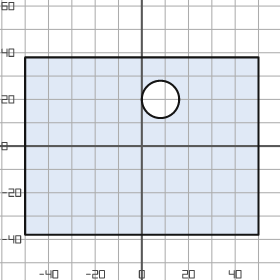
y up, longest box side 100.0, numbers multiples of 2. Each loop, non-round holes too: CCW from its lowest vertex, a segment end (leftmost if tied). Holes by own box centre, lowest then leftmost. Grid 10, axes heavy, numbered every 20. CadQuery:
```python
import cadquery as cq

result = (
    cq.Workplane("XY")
    .moveTo(-50.0, -38.0)
    .lineTo(50.0, -38.0)
    .lineTo(50.0, 38.0)
    .lineTo(-50.0, 38.0)
    .close()
    .moveTo(8.0, 20.0)
    .circle(8.0)
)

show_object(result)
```